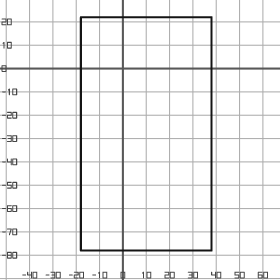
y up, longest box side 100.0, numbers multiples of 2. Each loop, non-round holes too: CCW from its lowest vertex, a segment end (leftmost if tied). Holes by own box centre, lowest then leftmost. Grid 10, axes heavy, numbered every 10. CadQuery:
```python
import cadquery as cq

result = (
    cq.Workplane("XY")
    .moveTo(-18.0, -78.0)
    .lineTo(38.0, -78.0)
    .lineTo(38.0, 22.0)
    .lineTo(-18.0, 22.0)
    .close()
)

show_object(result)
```